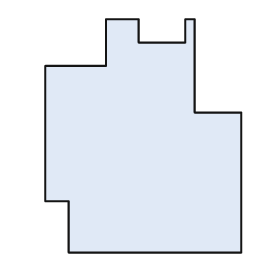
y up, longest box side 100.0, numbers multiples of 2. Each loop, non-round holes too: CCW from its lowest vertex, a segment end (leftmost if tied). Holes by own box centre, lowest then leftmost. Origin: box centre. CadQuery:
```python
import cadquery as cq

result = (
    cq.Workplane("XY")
    .moveTo(-32.0, -50.0)
    .lineTo(42.0, -50.0)
    .lineTo(42.0, 10.0)
    .lineTo(22.0, 10.0)
    .lineTo(22.0, 50.0)
    .lineTo(18.0, 50.0)
    .lineTo(18.0, 40.0)
    .lineTo(-2.0, 40.0)
    .lineTo(-2.0, 50.0)
    .lineTo(-16.0, 50.0)
    .lineTo(-16.0, 30.0)
    .lineTo(-42.0, 30.0)
    .lineTo(-42.0, -28.0)
    .lineTo(-32.0, -28.0)
    .close()
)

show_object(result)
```